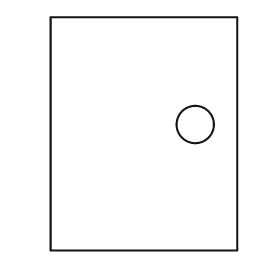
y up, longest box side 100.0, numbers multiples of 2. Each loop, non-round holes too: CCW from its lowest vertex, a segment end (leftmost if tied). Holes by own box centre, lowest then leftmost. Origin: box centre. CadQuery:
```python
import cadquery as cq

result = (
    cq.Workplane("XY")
    .moveTo(-40.0, -50.0)
    .lineTo(40.0, -50.0)
    .lineTo(40.0, 50.0)
    .lineTo(-40.0, 50.0)
    .close()
    .moveTo(22.0, 4.0)
    .circle(8.0)
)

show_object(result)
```